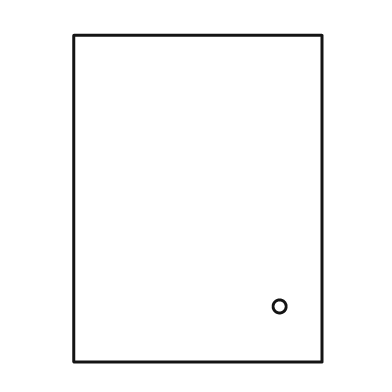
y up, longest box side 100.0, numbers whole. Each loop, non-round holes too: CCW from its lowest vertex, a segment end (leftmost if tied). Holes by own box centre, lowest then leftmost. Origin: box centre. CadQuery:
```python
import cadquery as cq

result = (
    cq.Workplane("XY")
    .moveTo(-38.0, -50.0)
    .lineTo(38.0, -50.0)
    .lineTo(38.0, 50.0)
    .lineTo(-38.0, 50.0)
    .close()
    .moveTo(25.0, -33.0)
    .circle(2.0)
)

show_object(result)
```